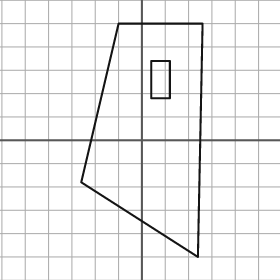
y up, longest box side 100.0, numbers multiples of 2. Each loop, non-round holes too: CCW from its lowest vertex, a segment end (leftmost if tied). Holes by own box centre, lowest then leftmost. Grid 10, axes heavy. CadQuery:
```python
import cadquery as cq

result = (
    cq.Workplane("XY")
    .moveTo(24.0, -50.0)
    .lineTo(26.0, 50.0)
    .lineTo(-10.0, 50.0)
    .lineTo(-26.0, -18.0)
    .close()
    .moveTo(4.0, 18.0)
    .lineTo(12.0, 18.0)
    .lineTo(12.0, 34.0)
    .lineTo(4.0, 34.0)
    .close()
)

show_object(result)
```